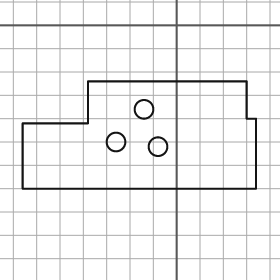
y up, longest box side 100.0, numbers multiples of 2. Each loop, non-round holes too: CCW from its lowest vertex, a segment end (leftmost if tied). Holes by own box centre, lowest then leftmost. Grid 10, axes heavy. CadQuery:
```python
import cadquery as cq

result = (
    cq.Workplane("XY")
    .moveTo(-66.0, -70.0)
    .lineTo(34.0, -70.0)
    .lineTo(34.0, -40.0)
    .lineTo(30.0, -40.0)
    .lineTo(30.0, -24.0)
    .lineTo(-38.0, -24.0)
    .lineTo(-38.0, -42.0)
    .lineTo(-66.0, -42.0)
    .close()
    .moveTo(-8.0, -52.0)
    .circle(4.0)
    .moveTo(-26.0, -50.0)
    .circle(4.0)
    .moveTo(-14.0, -36.0)
    .circle(4.0)
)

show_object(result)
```